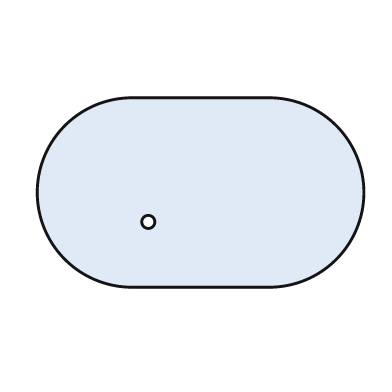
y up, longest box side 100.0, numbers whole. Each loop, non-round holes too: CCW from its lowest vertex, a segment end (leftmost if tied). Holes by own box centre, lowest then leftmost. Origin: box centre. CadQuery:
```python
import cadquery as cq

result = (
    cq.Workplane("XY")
    .moveTo(-21.0, -29.0)
    .lineTo(21.0, -29.0)
    .threePointArc((50.0, 0.0), (21.0, 29.0))
    .lineTo(-21.0, 29.0)
    .threePointArc((-50.0, 0.0), (-21.0, -29.0))
    .close()
    .moveTo(-16.0, -9.0)
    .circle(2.0)
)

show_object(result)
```